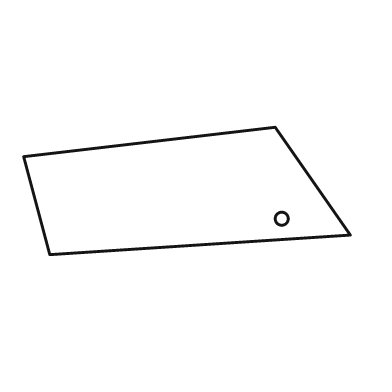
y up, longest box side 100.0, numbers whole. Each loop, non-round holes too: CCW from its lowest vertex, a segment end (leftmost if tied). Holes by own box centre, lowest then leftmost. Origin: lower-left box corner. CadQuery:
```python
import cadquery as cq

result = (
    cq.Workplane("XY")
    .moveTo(8.0, 0.0)
    .lineTo(100.0, 6.0)
    .lineTo(77.0, 39.0)
    .lineTo(0.0, 30.0)
    .close()
    .moveTo(79.0, 11.0)
    .circle(2.0)
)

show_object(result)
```